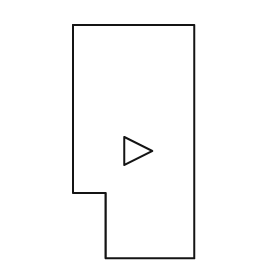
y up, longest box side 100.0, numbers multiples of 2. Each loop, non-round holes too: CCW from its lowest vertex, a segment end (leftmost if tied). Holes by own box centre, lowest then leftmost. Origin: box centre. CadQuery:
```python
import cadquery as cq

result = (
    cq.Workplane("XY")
    .moveTo(-12.0, -50.0)
    .lineTo(26.0, -50.0)
    .lineTo(26.0, 50.0)
    .lineTo(-26.0, 50.0)
    .lineTo(-26.0, -22.0)
    .lineTo(-12.0, -22.0)
    .close()
    .moveTo(-4.0, -10.0)
    .lineTo(8.0, -4.0)
    .lineTo(-4.0, 2.0)
    .close()
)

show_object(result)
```